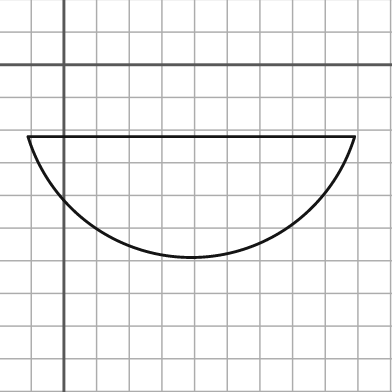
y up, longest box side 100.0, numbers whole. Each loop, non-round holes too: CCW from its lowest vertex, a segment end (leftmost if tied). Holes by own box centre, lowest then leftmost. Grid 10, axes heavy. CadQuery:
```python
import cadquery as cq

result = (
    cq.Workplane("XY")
    .moveTo(-11.0, -22.0)
    .threePointArc((39.0, -59.0), (89.0, -22.0))
    .close()
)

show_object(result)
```